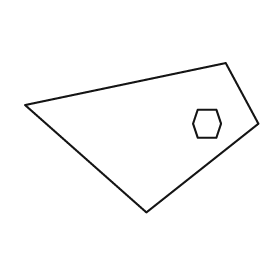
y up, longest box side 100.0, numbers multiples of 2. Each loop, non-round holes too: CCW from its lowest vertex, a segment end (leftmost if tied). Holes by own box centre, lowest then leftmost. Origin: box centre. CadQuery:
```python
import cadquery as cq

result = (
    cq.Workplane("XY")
    .moveTo(2.0, -32.0)
    .lineTo(50.0, 6.0)
    .lineTo(36.0, 32.0)
    .lineTo(-50.0, 14.0)
    .close()
    .moveTo(24.0, 0.0)
    .lineTo(32.0, 0.0)
    .lineTo(34.0, 6.0)
    .lineTo(32.0, 12.0)
    .lineTo(24.0, 12.0)
    .lineTo(22.0, 6.0)
    .close()
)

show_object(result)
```